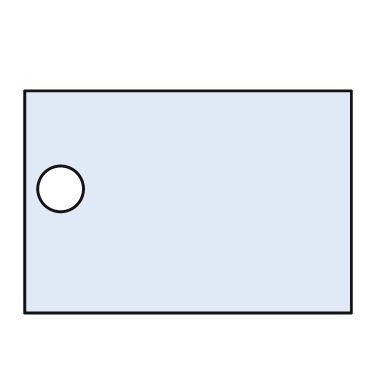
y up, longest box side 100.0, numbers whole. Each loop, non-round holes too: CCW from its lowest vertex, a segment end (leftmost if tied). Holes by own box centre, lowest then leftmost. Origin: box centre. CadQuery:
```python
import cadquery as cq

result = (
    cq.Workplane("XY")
    .moveTo(-50.0, -34.0)
    .lineTo(50.0, -34.0)
    .lineTo(50.0, 34.0)
    .lineTo(-50.0, 34.0)
    .close()
    .moveTo(-39.0, 4.0)
    .circle(7.0)
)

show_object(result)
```